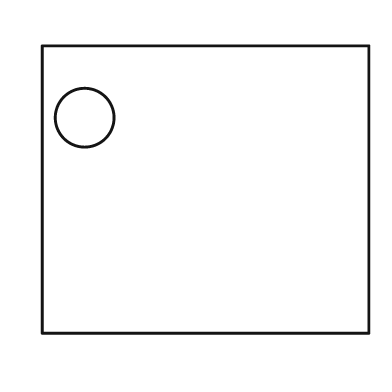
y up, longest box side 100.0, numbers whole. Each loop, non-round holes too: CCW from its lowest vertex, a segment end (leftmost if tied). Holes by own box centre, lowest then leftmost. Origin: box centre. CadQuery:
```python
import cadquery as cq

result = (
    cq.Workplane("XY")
    .moveTo(-50.0, -44.0)
    .lineTo(50.0, -44.0)
    .lineTo(50.0, 44.0)
    .lineTo(-50.0, 44.0)
    .close()
    .moveTo(-37.0, 22.0)
    .circle(9.0)
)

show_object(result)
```